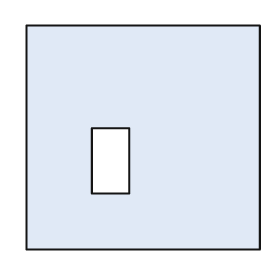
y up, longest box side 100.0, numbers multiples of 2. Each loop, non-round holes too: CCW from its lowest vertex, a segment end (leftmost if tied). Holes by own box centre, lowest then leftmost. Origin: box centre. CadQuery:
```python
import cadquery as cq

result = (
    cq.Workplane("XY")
    .moveTo(-50.0, -48.0)
    .lineTo(50.0, -48.0)
    .lineTo(50.0, 48.0)
    .lineTo(-50.0, 48.0)
    .close()
    .moveTo(-22.0, -24.0)
    .lineTo(-6.0, -24.0)
    .lineTo(-6.0, 4.0)
    .lineTo(-22.0, 4.0)
    .close()
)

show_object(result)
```